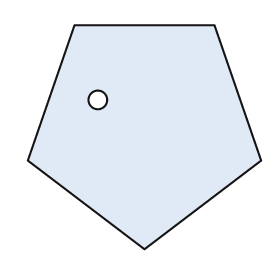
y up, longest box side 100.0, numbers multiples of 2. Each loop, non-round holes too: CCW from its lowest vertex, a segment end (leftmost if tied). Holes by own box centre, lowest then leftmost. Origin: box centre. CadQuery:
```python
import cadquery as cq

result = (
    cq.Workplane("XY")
    .moveTo(0.0, -48.0)
    .lineTo(50.0, -10.0)
    .lineTo(30.0, 48.0)
    .lineTo(-30.0, 48.0)
    .lineTo(-50.0, -10.0)
    .close()
    .moveTo(-20.0, 16.0)
    .circle(4.0)
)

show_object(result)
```